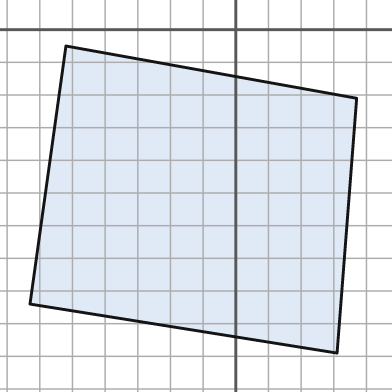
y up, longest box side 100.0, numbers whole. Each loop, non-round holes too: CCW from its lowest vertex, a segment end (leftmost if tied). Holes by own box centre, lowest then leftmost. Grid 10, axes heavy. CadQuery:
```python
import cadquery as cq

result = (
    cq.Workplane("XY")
    .moveTo(31.0, -99.0)
    .lineTo(37.0, -21.0)
    .lineTo(-52.0, -5.0)
    .lineTo(-63.0, -84.0)
    .close()
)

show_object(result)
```